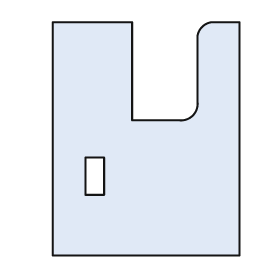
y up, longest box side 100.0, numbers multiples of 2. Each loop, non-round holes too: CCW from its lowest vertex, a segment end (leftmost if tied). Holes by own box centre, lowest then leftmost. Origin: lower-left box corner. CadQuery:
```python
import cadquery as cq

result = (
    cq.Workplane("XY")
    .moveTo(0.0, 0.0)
    .lineTo(80.0, 0.0)
    .lineTo(80.0, 100.0)
    .lineTo(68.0, 100.0)
    .threePointArc((64.0, 98.0), (62.0, 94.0))
    .lineTo(62.0, 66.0)
    .threePointArc((60.0, 60.0), (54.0, 58.0))
    .lineTo(34.0, 58.0)
    .lineTo(34.0, 100.0)
    .lineTo(0.0, 100.0)
    .close()
    .moveTo(14.0, 26.0)
    .lineTo(22.0, 26.0)
    .lineTo(22.0, 42.0)
    .lineTo(14.0, 42.0)
    .close()
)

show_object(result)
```